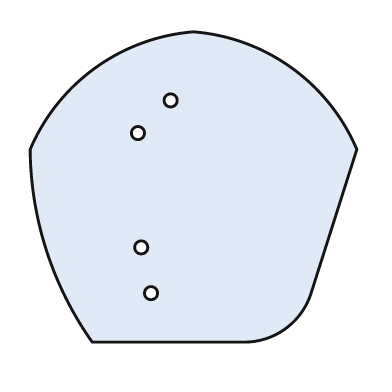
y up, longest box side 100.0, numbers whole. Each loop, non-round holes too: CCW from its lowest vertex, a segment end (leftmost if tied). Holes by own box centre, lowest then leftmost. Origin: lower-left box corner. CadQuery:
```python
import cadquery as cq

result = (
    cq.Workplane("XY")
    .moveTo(19.0, 0.0)
    .lineTo(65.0, 0.0)
    .threePointArc((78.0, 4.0), (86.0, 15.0))
    .lineTo(100.0, 59.0)
    .threePointArc((80.0, 84.0), (50.0, 95.0))
    .threePointArc((20.0, 84.0), (0.0, 59.0))
    .threePointArc((5.0, 28.0), (19.0, 0.0))
    .close()
    .moveTo(37.0, 15.0)
    .circle(2.0)
    .moveTo(34.0, 29.0)
    .circle(2.0)
    .moveTo(33.0, 64.0)
    .circle(2.0)
    .moveTo(43.0, 74.0)
    .circle(2.0)
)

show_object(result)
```